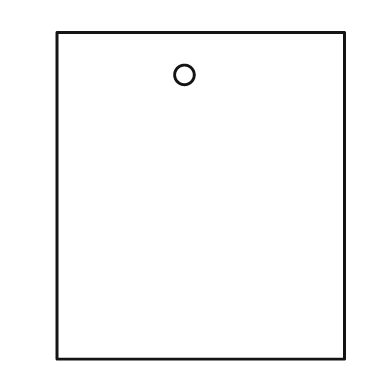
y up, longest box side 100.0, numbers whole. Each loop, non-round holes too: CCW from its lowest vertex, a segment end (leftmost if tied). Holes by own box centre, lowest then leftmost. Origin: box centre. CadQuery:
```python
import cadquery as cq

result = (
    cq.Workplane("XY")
    .moveTo(-44.0, -50.0)
    .lineTo(44.0, -50.0)
    .lineTo(44.0, 50.0)
    .lineTo(-44.0, 50.0)
    .close()
    .moveTo(-5.0, 37.0)
    .circle(3.0)
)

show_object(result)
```